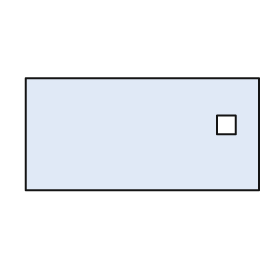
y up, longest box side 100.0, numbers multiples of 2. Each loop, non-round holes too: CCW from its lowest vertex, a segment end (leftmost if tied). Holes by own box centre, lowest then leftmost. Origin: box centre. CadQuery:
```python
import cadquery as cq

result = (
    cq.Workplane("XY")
    .moveTo(-50.0, -24.0)
    .lineTo(50.0, -24.0)
    .lineTo(50.0, 24.0)
    .lineTo(-50.0, 24.0)
    .close()
    .moveTo(32.0, 0.0)
    .lineTo(40.0, 0.0)
    .lineTo(40.0, 8.0)
    .lineTo(32.0, 8.0)
    .close()
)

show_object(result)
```